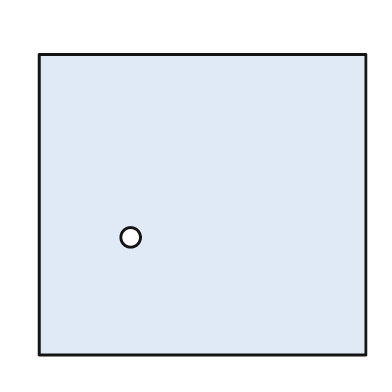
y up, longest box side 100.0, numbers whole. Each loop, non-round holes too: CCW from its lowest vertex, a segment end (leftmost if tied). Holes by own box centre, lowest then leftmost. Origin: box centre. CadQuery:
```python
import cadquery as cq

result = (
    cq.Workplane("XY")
    .moveTo(-50.0, -46.0)
    .lineTo(50.0, -46.0)
    .lineTo(50.0, 46.0)
    .lineTo(-50.0, 46.0)
    .close()
    .moveTo(-22.0, -10.0)
    .circle(3.0)
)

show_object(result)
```